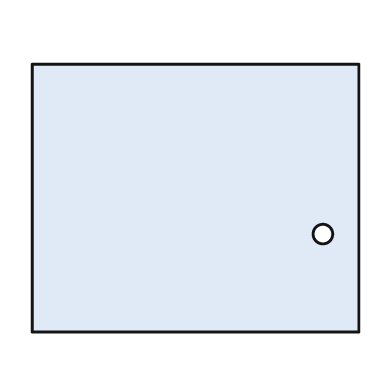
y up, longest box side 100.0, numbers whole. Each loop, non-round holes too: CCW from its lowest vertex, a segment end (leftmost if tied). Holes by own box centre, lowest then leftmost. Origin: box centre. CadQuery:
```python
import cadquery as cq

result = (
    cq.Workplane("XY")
    .moveTo(-50.0, -41.0)
    .lineTo(50.0, -41.0)
    .lineTo(50.0, 41.0)
    .lineTo(-50.0, 41.0)
    .close()
    .moveTo(39.0, -11.0)
    .circle(3.0)
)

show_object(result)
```